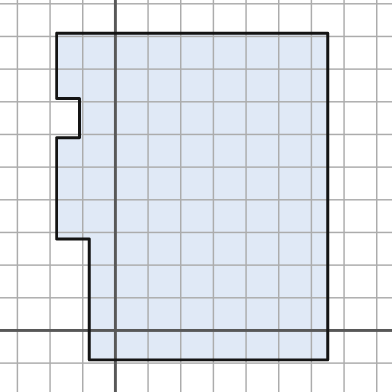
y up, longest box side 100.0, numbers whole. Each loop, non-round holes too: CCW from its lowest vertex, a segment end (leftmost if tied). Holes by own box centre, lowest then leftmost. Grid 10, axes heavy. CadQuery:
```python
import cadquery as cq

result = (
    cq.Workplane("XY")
    .moveTo(-8.0, -9.0)
    .lineTo(65.0, -9.0)
    .lineTo(65.0, 91.0)
    .lineTo(-18.0, 91.0)
    .lineTo(-18.0, 71.0)
    .lineTo(-11.0, 71.0)
    .lineTo(-11.0, 59.0)
    .lineTo(-18.0, 59.0)
    .lineTo(-18.0, 28.0)
    .lineTo(-8.0, 28.0)
    .close()
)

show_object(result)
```